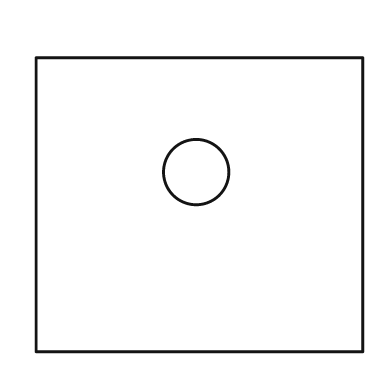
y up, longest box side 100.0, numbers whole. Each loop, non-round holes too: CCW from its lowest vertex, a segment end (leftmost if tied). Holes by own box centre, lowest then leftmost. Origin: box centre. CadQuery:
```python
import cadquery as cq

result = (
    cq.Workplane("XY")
    .moveTo(-50.0, -45.0)
    .lineTo(50.0, -45.0)
    .lineTo(50.0, 45.0)
    .lineTo(-50.0, 45.0)
    .close()
    .moveTo(-1.0, 10.0)
    .circle(10.0)
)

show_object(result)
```